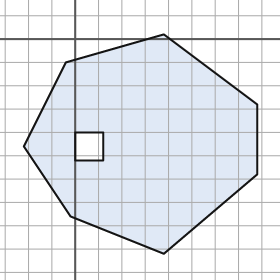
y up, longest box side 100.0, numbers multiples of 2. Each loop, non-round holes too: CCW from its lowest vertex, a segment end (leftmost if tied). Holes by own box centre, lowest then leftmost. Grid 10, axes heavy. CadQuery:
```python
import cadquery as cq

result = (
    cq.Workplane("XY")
    .moveTo(38.0, -92.0)
    .lineTo(78.0, -58.0)
    .lineTo(78.0, -28.0)
    .lineTo(38.0, 2.0)
    .lineTo(-4.0, -10.0)
    .lineTo(-22.0, -46.0)
    .lineTo(-2.0, -76.0)
    .close()
    .moveTo(0.0, -52.0)
    .lineTo(12.0, -52.0)
    .lineTo(12.0, -40.0)
    .lineTo(0.0, -40.0)
    .close()
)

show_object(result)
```